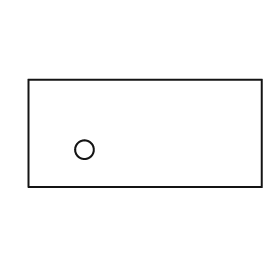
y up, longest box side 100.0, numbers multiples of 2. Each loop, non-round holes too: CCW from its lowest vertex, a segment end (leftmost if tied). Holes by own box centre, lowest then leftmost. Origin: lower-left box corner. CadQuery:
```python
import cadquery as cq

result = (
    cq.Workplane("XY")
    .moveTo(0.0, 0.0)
    .lineTo(100.0, 0.0)
    .lineTo(100.0, 46.0)
    .lineTo(0.0, 46.0)
    .close()
    .moveTo(24.0, 16.0)
    .circle(4.0)
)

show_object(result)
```